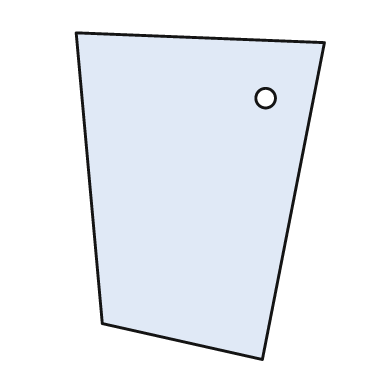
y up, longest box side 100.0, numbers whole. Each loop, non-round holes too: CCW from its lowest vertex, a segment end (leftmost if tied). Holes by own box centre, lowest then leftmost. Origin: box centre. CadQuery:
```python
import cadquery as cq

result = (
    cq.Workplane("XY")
    .moveTo(19.0, -50.0)
    .lineTo(38.0, 47.0)
    .lineTo(-38.0, 50.0)
    .lineTo(-30.0, -39.0)
    .close()
    .moveTo(20.0, 30.0)
    .circle(3.0)
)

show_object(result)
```